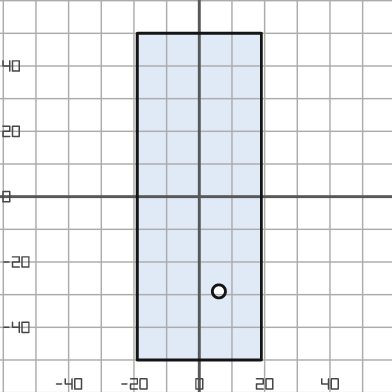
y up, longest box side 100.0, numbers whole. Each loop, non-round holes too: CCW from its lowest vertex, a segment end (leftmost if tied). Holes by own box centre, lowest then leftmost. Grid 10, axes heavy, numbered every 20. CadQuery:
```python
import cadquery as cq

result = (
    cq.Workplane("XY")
    .moveTo(-19.0, -50.0)
    .lineTo(19.0, -50.0)
    .lineTo(19.0, 50.0)
    .lineTo(-19.0, 50.0)
    .close()
    .moveTo(6.0, -29.0)
    .circle(2.0)
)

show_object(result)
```